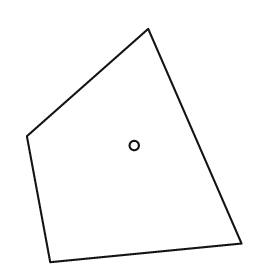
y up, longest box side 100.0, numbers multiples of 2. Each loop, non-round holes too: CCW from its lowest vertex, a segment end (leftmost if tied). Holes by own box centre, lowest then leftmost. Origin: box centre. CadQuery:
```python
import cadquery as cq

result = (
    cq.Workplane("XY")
    .moveTo(-36.0, -50.0)
    .lineTo(46.0, -42.0)
    .lineTo(6.0, 50.0)
    .lineTo(-46.0, 4.0)
    .close()
    .moveTo(0.0, 0.0)
    .circle(2.0)
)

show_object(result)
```